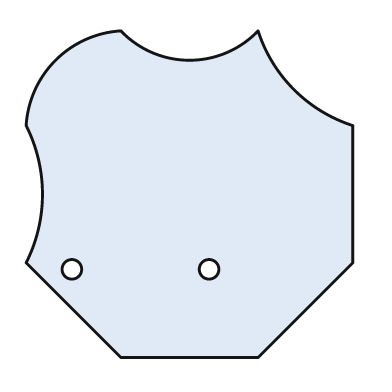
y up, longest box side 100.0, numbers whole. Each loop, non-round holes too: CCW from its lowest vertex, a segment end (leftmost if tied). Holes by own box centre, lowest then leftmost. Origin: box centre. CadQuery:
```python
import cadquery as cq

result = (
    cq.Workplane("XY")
    .moveTo(-21.0, -50.0)
    .lineTo(21.0, -50.0)
    .lineTo(50.0, -21.0)
    .lineTo(50.0, 21.0)
    .threePointArc((32.0, 32.0), (21.0, 50.0))
    .threePointArc((0.0, 41.0), (-21.0, 50.0))
    .threePointArc((-41.0, 41.0), (-50.0, 21.0))
    .threePointArc((-45.0, 0.0), (-50.0, -21.0))
    .close()
    .moveTo(-36.0, -23.0)
    .circle(3.0)
    .moveTo(6.0, -23.0)
    .circle(3.0)
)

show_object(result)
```